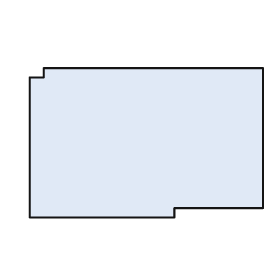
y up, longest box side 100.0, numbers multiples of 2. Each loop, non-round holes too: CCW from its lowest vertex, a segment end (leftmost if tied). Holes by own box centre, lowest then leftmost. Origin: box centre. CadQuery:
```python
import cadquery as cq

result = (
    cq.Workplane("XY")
    .moveTo(-50.0, -32.0)
    .lineTo(12.0, -32.0)
    .lineTo(12.0, -28.0)
    .lineTo(50.0, -28.0)
    .lineTo(50.0, 32.0)
    .lineTo(-44.0, 32.0)
    .lineTo(-44.0, 28.0)
    .lineTo(-50.0, 28.0)
    .close()
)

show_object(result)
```